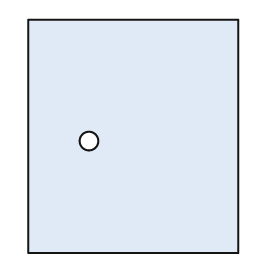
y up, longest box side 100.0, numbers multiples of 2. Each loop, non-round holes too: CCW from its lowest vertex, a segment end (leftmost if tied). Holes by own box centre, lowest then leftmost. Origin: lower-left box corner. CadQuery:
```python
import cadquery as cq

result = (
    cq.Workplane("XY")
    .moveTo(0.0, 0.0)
    .lineTo(90.0, 0.0)
    .lineTo(90.0, 100.0)
    .lineTo(0.0, 100.0)
    .close()
    .moveTo(26.0, 48.0)
    .circle(4.0)
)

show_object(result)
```